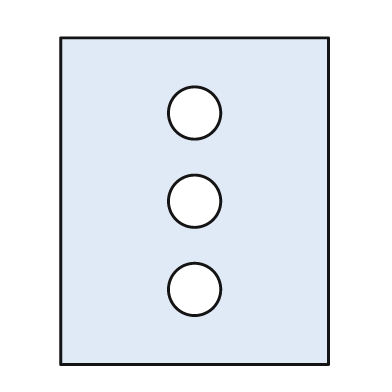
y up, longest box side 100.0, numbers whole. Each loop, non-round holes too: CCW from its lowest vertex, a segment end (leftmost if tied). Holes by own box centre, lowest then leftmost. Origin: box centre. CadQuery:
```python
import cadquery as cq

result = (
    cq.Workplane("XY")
    .moveTo(-41.0, -50.0)
    .lineTo(41.0, -50.0)
    .lineTo(41.0, 50.0)
    .lineTo(-41.0, 50.0)
    .close()
    .moveTo(0.0, -27.0)
    .circle(8.0)
    .moveTo(0.0, 0.0)
    .circle(8.0)
    .moveTo(0.0, 27.0)
    .circle(8.0)
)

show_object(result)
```